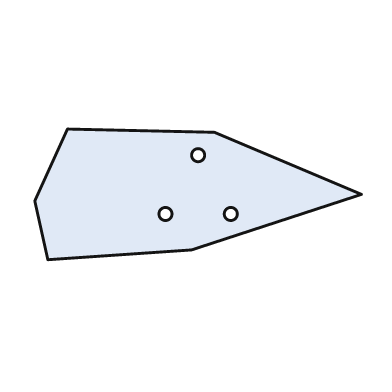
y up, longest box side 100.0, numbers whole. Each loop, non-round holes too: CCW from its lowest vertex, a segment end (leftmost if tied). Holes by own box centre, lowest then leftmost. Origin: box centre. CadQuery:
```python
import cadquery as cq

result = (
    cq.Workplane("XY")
    .moveTo(-46.0, -20.0)
    .lineTo(-2.0, -17.0)
    .lineTo(50.0, 0.0)
    .lineTo(5.0, 19.0)
    .lineTo(-40.0, 20.0)
    .lineTo(-50.0, -2.0)
    .close()
    .moveTo(-10.0, -6.0)
    .circle(2.0)
    .moveTo(10.0, -6.0)
    .circle(2.0)
    .moveTo(0.0, 12.0)
    .circle(2.0)
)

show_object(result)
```